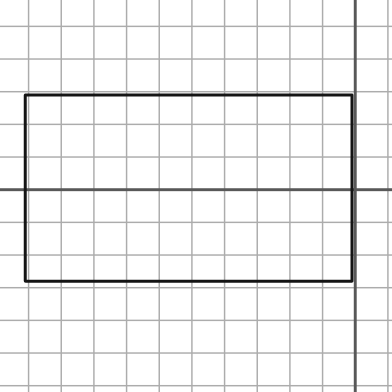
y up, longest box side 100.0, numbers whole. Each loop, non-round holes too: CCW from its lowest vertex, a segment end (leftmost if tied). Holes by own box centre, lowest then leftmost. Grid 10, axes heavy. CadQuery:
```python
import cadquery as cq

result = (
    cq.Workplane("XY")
    .moveTo(-101.0, -28.0)
    .lineTo(-1.0, -28.0)
    .lineTo(-1.0, 29.0)
    .lineTo(-101.0, 29.0)
    .close()
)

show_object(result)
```